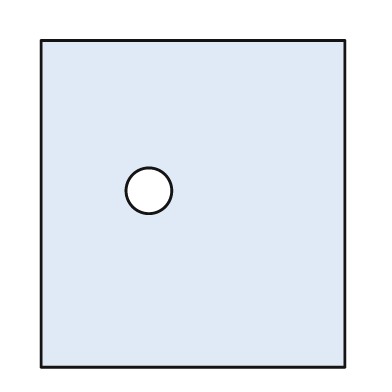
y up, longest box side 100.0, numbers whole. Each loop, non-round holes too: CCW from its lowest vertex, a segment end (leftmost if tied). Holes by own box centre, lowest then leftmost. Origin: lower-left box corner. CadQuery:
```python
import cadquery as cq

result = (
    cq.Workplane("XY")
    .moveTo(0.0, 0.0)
    .lineTo(93.0, 0.0)
    .lineTo(93.0, 100.0)
    .lineTo(0.0, 100.0)
    .close()
    .moveTo(33.0, 54.0)
    .circle(7.0)
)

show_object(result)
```